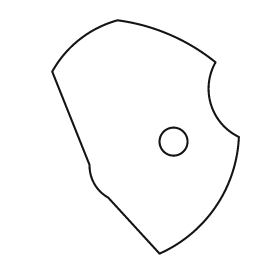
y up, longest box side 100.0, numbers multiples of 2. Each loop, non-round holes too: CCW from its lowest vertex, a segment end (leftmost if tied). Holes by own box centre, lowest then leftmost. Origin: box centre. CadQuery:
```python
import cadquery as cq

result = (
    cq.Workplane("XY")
    .moveTo(6.0, -50.0)
    .threePointArc((30.0, -30.0), (40.0, 0.0))
    .threePointArc((28.0, 14.0), (30.0, 32.0))
    .threePointArc((10.0, 44.0), (-12.0, 50.0))
    .threePointArc((-28.0, 42.0), (-40.0, 28.0))
    .lineTo(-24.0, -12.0)
    .threePointArc((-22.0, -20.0), (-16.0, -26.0))
    .close()
    .moveTo(12.0, -2.0)
    .circle(6.0)
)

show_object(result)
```